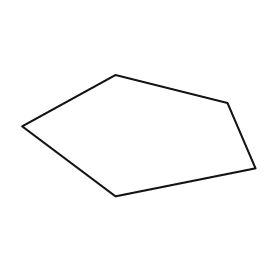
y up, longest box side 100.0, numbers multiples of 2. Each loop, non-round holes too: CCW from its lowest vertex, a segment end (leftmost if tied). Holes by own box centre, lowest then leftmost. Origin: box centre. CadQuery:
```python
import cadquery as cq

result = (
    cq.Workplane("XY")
    .moveTo(-10.0, -26.0)
    .lineTo(50.0, -14.0)
    .lineTo(38.0, 14.0)
    .lineTo(-10.0, 26.0)
    .lineTo(-50.0, 4.0)
    .close()
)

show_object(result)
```